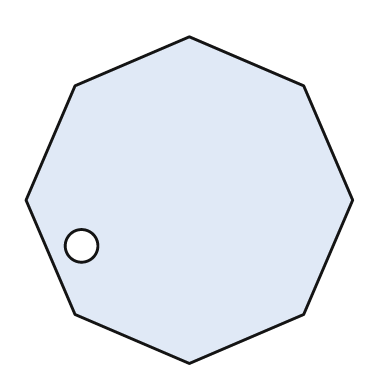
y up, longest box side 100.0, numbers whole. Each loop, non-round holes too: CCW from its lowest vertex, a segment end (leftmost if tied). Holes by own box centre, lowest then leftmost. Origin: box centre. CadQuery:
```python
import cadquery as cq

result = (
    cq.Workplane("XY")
    .moveTo(0.0, -50.0)
    .lineTo(35.0, -35.0)
    .lineTo(50.0, 0.0)
    .lineTo(35.0, 35.0)
    .lineTo(0.0, 50.0)
    .lineTo(-35.0, 35.0)
    .lineTo(-50.0, 0.0)
    .lineTo(-35.0, -35.0)
    .close()
    .moveTo(-33.0, -14.0)
    .circle(5.0)
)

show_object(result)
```